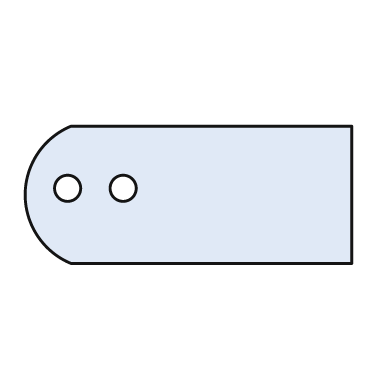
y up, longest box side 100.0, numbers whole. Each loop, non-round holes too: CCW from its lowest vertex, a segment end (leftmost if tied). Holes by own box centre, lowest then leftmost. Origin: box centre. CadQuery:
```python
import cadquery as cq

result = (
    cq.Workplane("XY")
    .moveTo(-36.0, -21.0)
    .lineTo(50.0, -21.0)
    .lineTo(50.0, 21.0)
    .lineTo(-36.0, 21.0)
    .threePointArc((-50.0, 0.0), (-36.0, -21.0))
    .close()
    .moveTo(-37.0, 2.0)
    .circle(4.0)
    .moveTo(-20.0, 2.0)
    .circle(4.0)
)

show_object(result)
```